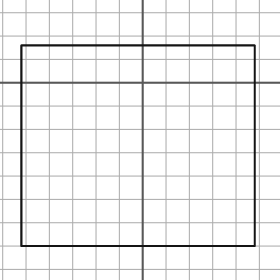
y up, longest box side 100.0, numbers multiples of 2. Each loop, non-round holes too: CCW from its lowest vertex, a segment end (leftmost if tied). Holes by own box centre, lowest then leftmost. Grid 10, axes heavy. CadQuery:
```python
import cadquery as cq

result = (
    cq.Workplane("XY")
    .moveTo(-52.0, -70.0)
    .lineTo(48.0, -70.0)
    .lineTo(48.0, 16.0)
    .lineTo(-52.0, 16.0)
    .close()
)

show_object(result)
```